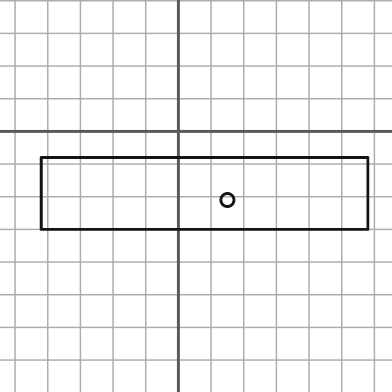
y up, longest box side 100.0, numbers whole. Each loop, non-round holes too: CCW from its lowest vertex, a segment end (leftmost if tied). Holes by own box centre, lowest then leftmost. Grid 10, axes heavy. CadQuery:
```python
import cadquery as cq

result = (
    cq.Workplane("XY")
    .moveTo(-42.0, -30.0)
    .lineTo(58.0, -30.0)
    .lineTo(58.0, -8.0)
    .lineTo(-42.0, -8.0)
    .close()
    .moveTo(15.0, -21.0)
    .circle(2.0)
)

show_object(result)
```